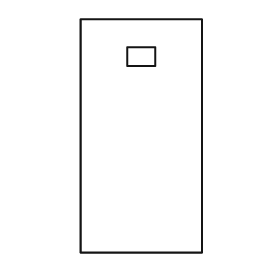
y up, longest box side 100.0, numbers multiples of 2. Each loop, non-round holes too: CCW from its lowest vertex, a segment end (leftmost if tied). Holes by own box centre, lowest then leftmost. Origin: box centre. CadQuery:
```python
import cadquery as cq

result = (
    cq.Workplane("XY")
    .moveTo(-26.0, -50.0)
    .lineTo(26.0, -50.0)
    .lineTo(26.0, 50.0)
    .lineTo(-26.0, 50.0)
    .close()
    .moveTo(-6.0, 30.0)
    .lineTo(6.0, 30.0)
    .lineTo(6.0, 38.0)
    .lineTo(-6.0, 38.0)
    .close()
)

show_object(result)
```